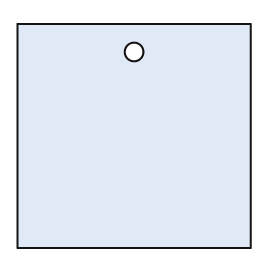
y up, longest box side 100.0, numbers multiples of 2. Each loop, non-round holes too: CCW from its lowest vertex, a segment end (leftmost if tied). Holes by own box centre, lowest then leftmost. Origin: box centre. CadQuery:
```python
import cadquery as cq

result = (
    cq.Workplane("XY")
    .moveTo(-50.0, -48.0)
    .lineTo(50.0, -48.0)
    .lineTo(50.0, 48.0)
    .lineTo(-50.0, 48.0)
    .close()
    .moveTo(0.0, 36.0)
    .circle(4.0)
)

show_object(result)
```